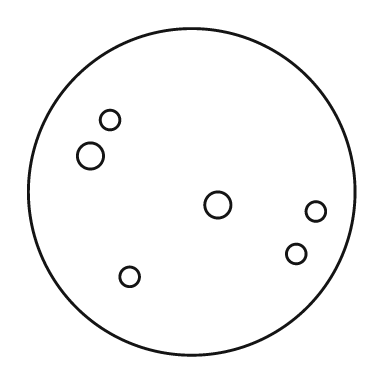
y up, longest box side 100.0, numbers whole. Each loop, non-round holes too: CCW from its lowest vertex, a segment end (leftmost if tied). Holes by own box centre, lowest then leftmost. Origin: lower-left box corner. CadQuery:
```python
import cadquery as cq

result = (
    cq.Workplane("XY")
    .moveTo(50.0, 50.0)
    .circle(50.0)
    .moveTo(31.0, 24.0)
    .circle(3.0)
    .moveTo(82.0, 31.0)
    .circle(3.0)
    .moveTo(88.0, 44.0)
    .circle(3.0)
    .moveTo(58.0, 46.0)
    .circle(4.0)
    .moveTo(19.0, 61.0)
    .circle(4.0)
    .moveTo(25.0, 72.0)
    .circle(3.0)
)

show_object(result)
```